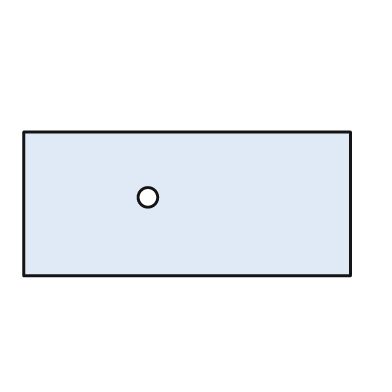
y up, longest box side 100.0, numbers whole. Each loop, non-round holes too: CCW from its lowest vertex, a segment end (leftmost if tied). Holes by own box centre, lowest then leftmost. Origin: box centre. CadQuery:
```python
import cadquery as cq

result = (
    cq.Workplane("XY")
    .moveTo(-50.0, -22.0)
    .lineTo(50.0, -22.0)
    .lineTo(50.0, 22.0)
    .lineTo(-50.0, 22.0)
    .close()
    .moveTo(-12.0, 2.0)
    .circle(3.0)
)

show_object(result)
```